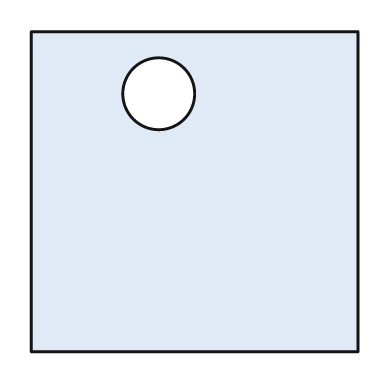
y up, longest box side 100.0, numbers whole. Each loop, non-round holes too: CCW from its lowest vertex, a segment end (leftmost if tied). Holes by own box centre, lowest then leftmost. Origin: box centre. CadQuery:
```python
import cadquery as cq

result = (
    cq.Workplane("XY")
    .moveTo(-50.0, -49.0)
    .lineTo(50.0, -49.0)
    .lineTo(50.0, 49.0)
    .lineTo(-50.0, 49.0)
    .close()
    .moveTo(-11.0, 30.0)
    .circle(11.0)
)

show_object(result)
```